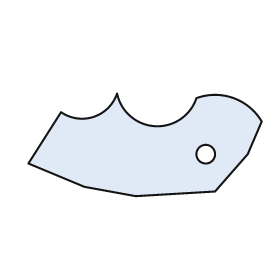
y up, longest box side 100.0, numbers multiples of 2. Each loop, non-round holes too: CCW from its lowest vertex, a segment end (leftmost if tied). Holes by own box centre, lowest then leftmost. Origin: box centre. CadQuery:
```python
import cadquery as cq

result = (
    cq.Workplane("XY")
    .moveTo(-4.0, -22.0)
    .lineTo(30.0, -20.0)
    .lineTo(44.0, -4.0)
    .lineTo(50.0, 10.0)
    .threePointArc((38.0, 20.0), (22.0, 20.0))
    .threePointArc((4.0, 8.0), (-12.0, 22.0))
    .threePointArc((-22.0, 12.0), (-36.0, 14.0))
    .lineTo(-50.0, -8.0)
    .lineTo(-26.0, -18.0)
    .close()
    .moveTo(26.0, -4.0)
    .circle(4.0)
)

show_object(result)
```